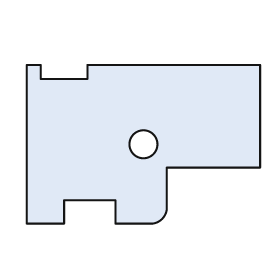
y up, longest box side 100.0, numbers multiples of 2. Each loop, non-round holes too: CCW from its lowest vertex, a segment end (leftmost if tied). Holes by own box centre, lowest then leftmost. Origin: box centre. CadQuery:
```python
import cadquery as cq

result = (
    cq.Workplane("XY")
    .moveTo(-50.0, -34.0)
    .lineTo(-34.0, -34.0)
    .lineTo(-34.0, -24.0)
    .lineTo(-12.0, -24.0)
    .lineTo(-12.0, -34.0)
    .lineTo(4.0, -34.0)
    .threePointArc((8.0, -32.0), (10.0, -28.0))
    .lineTo(10.0, -10.0)
    .lineTo(50.0, -10.0)
    .lineTo(50.0, 34.0)
    .lineTo(-24.0, 34.0)
    .lineTo(-24.0, 28.0)
    .lineTo(-44.0, 28.0)
    .lineTo(-44.0, 34.0)
    .lineTo(-50.0, 34.0)
    .close()
    .moveTo(0.0, 0.0)
    .circle(6.0)
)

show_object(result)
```